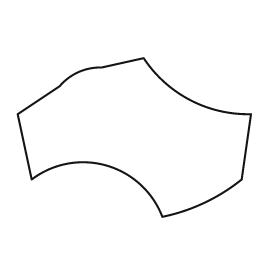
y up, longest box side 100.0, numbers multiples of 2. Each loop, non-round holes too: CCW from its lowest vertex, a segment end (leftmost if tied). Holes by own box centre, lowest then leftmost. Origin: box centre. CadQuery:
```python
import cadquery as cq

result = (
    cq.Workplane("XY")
    .moveTo(12.0, -34.0)
    .threePointArc((30.0, -28.0), (46.0, -18.0))
    .lineTo(50.0, 10.0)
    .threePointArc((24.0, 16.0), (4.0, 34.0))
    .lineTo(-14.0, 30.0)
    .threePointArc((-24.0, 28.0), (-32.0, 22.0))
    .lineTo(-50.0, 10.0)
    .lineTo(-44.0, -18.0)
    .threePointArc((-12.0, -12.0), (12.0, -34.0))
    .close()
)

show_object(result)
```